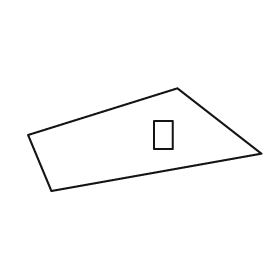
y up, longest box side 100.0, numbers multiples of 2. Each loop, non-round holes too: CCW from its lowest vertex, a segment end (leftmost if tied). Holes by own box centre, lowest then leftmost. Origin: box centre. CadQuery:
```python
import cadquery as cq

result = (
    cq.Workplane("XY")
    .moveTo(-40.0, -22.0)
    .lineTo(50.0, -6.0)
    .lineTo(14.0, 22.0)
    .lineTo(-50.0, 2.0)
    .close()
    .moveTo(4.0, -4.0)
    .lineTo(12.0, -4.0)
    .lineTo(12.0, 8.0)
    .lineTo(4.0, 8.0)
    .close()
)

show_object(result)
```